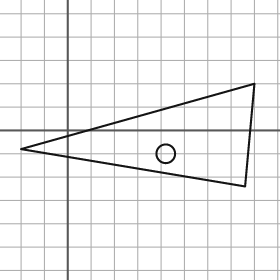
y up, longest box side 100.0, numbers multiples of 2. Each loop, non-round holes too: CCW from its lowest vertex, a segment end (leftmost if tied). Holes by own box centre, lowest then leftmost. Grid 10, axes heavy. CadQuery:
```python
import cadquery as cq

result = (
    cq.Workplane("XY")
    .moveTo(76.0, -24.0)
    .lineTo(80.0, 20.0)
    .lineTo(-20.0, -8.0)
    .close()
    .moveTo(42.0, -10.0)
    .circle(4.0)
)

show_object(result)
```